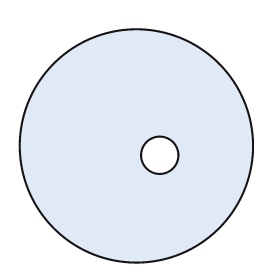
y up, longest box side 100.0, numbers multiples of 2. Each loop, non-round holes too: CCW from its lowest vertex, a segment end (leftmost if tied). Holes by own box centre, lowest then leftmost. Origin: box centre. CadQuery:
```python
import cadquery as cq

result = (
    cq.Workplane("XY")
    .moveTo(0.0, 0.0)
    .circle(50.0)
    .moveTo(10.0, -4.0)
    .circle(8.0)
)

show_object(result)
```